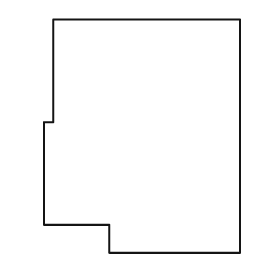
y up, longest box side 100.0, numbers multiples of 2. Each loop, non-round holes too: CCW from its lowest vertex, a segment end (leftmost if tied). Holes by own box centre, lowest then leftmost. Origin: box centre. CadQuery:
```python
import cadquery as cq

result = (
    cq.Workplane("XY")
    .moveTo(-14.0, -50.0)
    .lineTo(42.0, -50.0)
    .lineTo(42.0, 50.0)
    .lineTo(-38.0, 50.0)
    .lineTo(-38.0, 6.0)
    .lineTo(-42.0, 6.0)
    .lineTo(-42.0, -38.0)
    .lineTo(-14.0, -38.0)
    .close()
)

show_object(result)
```